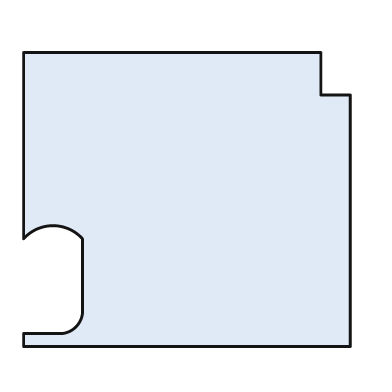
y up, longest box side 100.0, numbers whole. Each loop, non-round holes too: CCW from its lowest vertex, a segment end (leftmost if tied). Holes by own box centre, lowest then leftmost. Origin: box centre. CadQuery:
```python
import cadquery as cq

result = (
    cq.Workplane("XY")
    .moveTo(-50.0, -45.0)
    .lineTo(50.0, -45.0)
    .lineTo(50.0, 32.0)
    .lineTo(41.0, 32.0)
    .lineTo(41.0, 45.0)
    .lineTo(-50.0, 45.0)
    .lineTo(-50.0, -12.0)
    .threePointArc((-41.0, -8.0), (-32.0, -12.0))
    .lineTo(-32.0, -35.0)
    .threePointArc((-34.0, -39.0), (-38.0, -41.0))
    .lineTo(-50.0, -41.0)
    .close()
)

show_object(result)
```